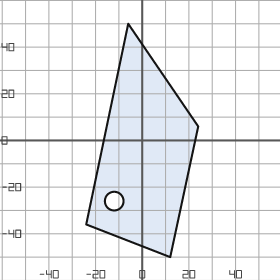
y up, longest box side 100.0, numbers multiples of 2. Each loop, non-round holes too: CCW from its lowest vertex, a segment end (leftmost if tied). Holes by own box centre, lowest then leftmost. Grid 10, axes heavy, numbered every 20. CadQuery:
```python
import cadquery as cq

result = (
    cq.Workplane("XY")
    .moveTo(12.0, -50.0)
    .lineTo(24.0, 6.0)
    .lineTo(-6.0, 50.0)
    .lineTo(-24.0, -36.0)
    .close()
    .moveTo(-12.0, -26.0)
    .circle(4.0)
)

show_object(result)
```